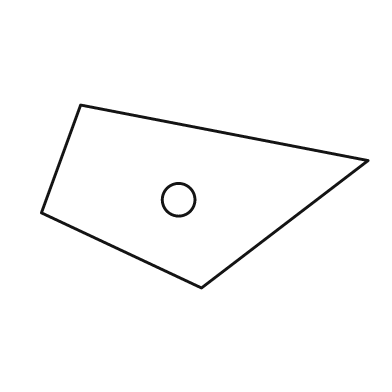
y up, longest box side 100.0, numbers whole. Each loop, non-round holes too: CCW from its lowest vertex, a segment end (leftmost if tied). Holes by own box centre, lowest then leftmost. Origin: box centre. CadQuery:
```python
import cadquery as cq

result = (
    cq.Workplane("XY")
    .moveTo(-1.0, -28.0)
    .lineTo(50.0, 11.0)
    .lineTo(-38.0, 28.0)
    .lineTo(-50.0, -5.0)
    .close()
    .moveTo(-8.0, -1.0)
    .circle(5.0)
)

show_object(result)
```